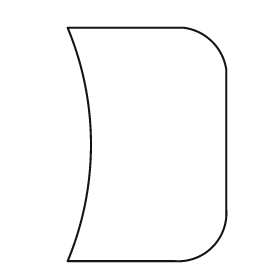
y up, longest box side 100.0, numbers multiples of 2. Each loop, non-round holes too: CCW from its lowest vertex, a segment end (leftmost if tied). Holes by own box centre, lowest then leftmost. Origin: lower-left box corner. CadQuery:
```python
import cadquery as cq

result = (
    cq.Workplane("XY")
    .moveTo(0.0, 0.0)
    .lineTo(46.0, 0.0)
    .threePointArc((62.0, 6.0), (68.0, 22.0))
    .lineTo(68.0, 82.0)
    .threePointArc((62.0, 94.0), (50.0, 100.0))
    .lineTo(0.0, 100.0)
    .threePointArc((10.0, 50.0), (0.0, 0.0))
    .close()
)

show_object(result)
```